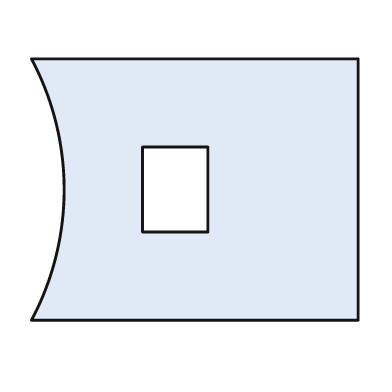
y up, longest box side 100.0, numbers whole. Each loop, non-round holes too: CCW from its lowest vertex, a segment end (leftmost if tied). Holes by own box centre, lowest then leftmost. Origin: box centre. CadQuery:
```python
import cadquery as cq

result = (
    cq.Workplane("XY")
    .moveTo(-50.0, -40.0)
    .lineTo(50.0, -40.0)
    .lineTo(50.0, 40.0)
    .lineTo(-50.0, 40.0)
    .threePointArc((-40.0, 0.0), (-50.0, -40.0))
    .close()
    .moveTo(-16.0, -13.0)
    .lineTo(4.0, -13.0)
    .lineTo(4.0, 13.0)
    .lineTo(-16.0, 13.0)
    .close()
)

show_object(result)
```